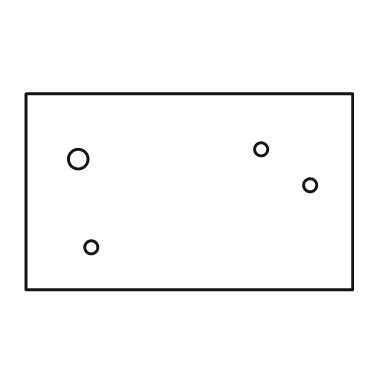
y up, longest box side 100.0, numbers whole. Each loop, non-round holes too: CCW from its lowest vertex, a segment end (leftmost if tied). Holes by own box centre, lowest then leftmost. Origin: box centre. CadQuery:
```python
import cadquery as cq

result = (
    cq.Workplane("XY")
    .moveTo(-50.0, -30.0)
    .lineTo(50.0, -30.0)
    .lineTo(50.0, 30.0)
    .lineTo(-50.0, 30.0)
    .close()
    .moveTo(-30.0, -17.0)
    .circle(2.0)
    .moveTo(37.0, 2.0)
    .circle(2.0)
    .moveTo(-34.0, 10.0)
    .circle(3.0)
    .moveTo(22.0, 13.0)
    .circle(2.0)
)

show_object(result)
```